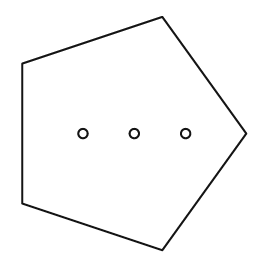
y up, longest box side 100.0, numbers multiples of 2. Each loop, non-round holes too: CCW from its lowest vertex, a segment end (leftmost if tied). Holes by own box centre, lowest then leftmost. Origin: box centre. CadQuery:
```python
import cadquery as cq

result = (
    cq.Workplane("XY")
    .moveTo(12.0, -50.0)
    .lineTo(48.0, 0.0)
    .lineTo(12.0, 50.0)
    .lineTo(-48.0, 30.0)
    .lineTo(-48.0, -30.0)
    .close()
    .moveTo(-22.0, 0.0)
    .circle(2.0)
    .moveTo(0.0, 0.0)
    .circle(2.0)
    .moveTo(22.0, 0.0)
    .circle(2.0)
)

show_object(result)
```